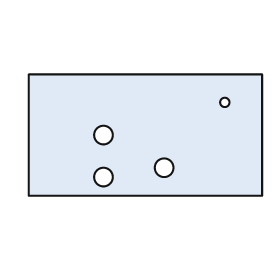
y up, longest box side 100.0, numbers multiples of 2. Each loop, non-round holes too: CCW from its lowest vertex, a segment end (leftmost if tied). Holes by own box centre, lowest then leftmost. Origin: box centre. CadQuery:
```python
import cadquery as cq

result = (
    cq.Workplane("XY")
    .moveTo(-50.0, -26.0)
    .lineTo(50.0, -26.0)
    .lineTo(50.0, 26.0)
    .lineTo(-50.0, 26.0)
    .close()
    .moveTo(-18.0, -18.0)
    .circle(4.0)
    .moveTo(8.0, -14.0)
    .circle(4.0)
    .moveTo(-18.0, 0.0)
    .circle(4.0)
    .moveTo(34.0, 14.0)
    .circle(2.0)
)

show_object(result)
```